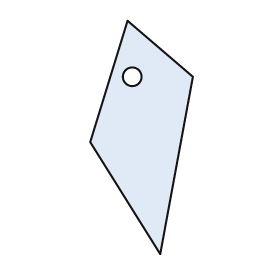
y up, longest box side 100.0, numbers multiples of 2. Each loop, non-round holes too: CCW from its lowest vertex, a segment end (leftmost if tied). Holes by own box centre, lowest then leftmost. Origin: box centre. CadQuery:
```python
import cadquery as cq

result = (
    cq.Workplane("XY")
    .moveTo(8.0, -50.0)
    .lineTo(22.0, 26.0)
    .lineTo(-6.0, 50.0)
    .lineTo(-22.0, -2.0)
    .close()
    .moveTo(-4.0, 26.0)
    .circle(4.0)
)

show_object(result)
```